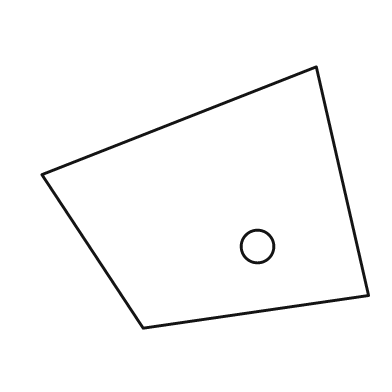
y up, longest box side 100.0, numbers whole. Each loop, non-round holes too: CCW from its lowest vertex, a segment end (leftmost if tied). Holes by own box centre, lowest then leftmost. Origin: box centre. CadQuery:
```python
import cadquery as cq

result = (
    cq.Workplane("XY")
    .moveTo(-19.0, -40.0)
    .lineTo(50.0, -30.0)
    .lineTo(34.0, 40.0)
    .lineTo(-50.0, 7.0)
    .close()
    .moveTo(16.0, -15.0)
    .circle(5.0)
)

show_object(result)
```